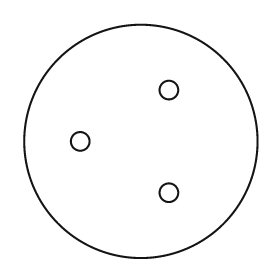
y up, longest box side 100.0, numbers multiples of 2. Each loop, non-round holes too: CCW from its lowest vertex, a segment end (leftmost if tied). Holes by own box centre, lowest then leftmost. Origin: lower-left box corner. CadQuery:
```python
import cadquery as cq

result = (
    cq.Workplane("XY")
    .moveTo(50.0, 50.0)
    .circle(50.0)
    .moveTo(62.0, 28.0)
    .circle(4.0)
    .moveTo(24.0, 50.0)
    .circle(4.0)
    .moveTo(62.0, 72.0)
    .circle(4.0)
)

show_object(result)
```